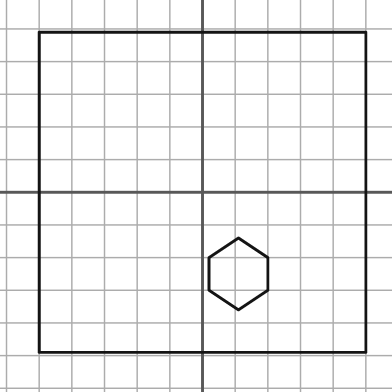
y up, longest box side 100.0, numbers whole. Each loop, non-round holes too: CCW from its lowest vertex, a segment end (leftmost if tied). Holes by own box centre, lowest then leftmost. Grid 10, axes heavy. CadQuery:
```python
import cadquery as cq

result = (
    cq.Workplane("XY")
    .moveTo(-50.0, -49.0)
    .lineTo(50.0, -49.0)
    .lineTo(50.0, 49.0)
    .lineTo(-50.0, 49.0)
    .close()
    .moveTo(11.0, -36.0)
    .lineTo(20.0, -30.0)
    .lineTo(20.0, -20.0)
    .lineTo(11.0, -14.0)
    .lineTo(2.0, -20.0)
    .lineTo(2.0, -30.0)
    .close()
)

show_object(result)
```